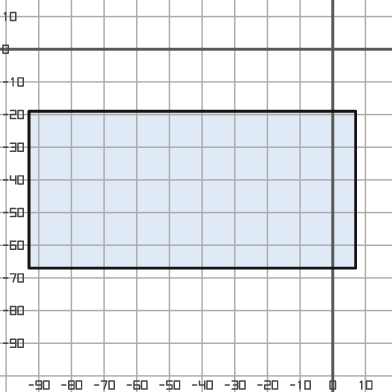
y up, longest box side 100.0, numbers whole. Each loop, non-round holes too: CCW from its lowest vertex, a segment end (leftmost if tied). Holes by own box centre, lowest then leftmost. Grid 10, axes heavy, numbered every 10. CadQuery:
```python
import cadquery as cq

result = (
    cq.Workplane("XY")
    .moveTo(-93.0, -67.0)
    .lineTo(7.0, -67.0)
    .lineTo(7.0, -19.0)
    .lineTo(-93.0, -19.0)
    .close()
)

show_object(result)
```